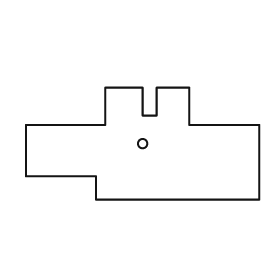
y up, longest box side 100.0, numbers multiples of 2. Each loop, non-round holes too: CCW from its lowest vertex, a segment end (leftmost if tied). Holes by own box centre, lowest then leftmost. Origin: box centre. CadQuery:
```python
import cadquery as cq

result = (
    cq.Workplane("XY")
    .moveTo(-20.0, -24.0)
    .lineTo(50.0, -24.0)
    .lineTo(50.0, 8.0)
    .lineTo(20.0, 8.0)
    .lineTo(20.0, 24.0)
    .lineTo(6.0, 24.0)
    .lineTo(6.0, 12.0)
    .lineTo(0.0, 12.0)
    .lineTo(0.0, 24.0)
    .lineTo(-16.0, 24.0)
    .lineTo(-16.0, 8.0)
    .lineTo(-50.0, 8.0)
    .lineTo(-50.0, -14.0)
    .lineTo(-20.0, -14.0)
    .close()
    .moveTo(0.0, 0.0)
    .circle(2.0)
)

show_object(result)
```